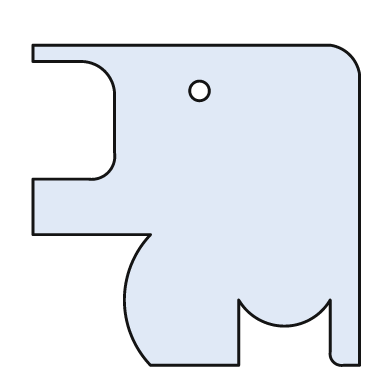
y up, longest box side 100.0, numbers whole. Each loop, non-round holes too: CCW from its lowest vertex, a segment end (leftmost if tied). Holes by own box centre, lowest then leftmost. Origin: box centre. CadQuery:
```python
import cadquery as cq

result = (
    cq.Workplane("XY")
    .moveTo(-14.0, -49.0)
    .lineTo(13.0, -49.0)
    .lineTo(13.0, -29.0)
    .threePointArc((27.0, -37.0), (41.0, -29.0))
    .lineTo(41.0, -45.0)
    .threePointArc((42.0, -48.0), (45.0, -49.0))
    .lineTo(50.0, -49.0)
    .lineTo(50.0, 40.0)
    .threePointArc((47.0, 46.0), (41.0, 49.0))
    .lineTo(-50.0, 49.0)
    .lineTo(-50.0, 44.0)
    .lineTo(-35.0, 44.0)
    .threePointArc((-28.0, 41.0), (-25.0, 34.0))
    .lineTo(-25.0, 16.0)
    .threePointArc((-27.0, 10.0), (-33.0, 8.0))
    .lineTo(-50.0, 8.0)
    .lineTo(-50.0, -9.0)
    .lineTo(-14.0, -9.0)
    .threePointArc((-22.0, -29.0), (-14.0, -49.0))
    .close()
    .moveTo(1.0, 35.0)
    .circle(3.0)
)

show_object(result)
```